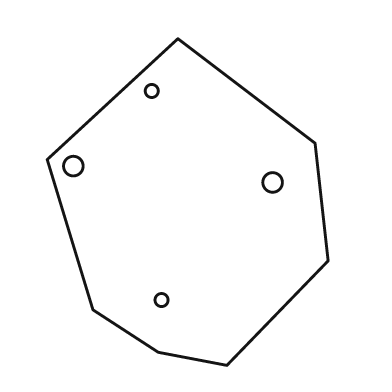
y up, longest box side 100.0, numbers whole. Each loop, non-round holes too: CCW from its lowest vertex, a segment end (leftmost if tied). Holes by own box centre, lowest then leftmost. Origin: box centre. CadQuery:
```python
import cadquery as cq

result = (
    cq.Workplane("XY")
    .moveTo(12.0, -50.0)
    .lineTo(43.0, -18.0)
    .lineTo(39.0, 18.0)
    .lineTo(-3.0, 50.0)
    .lineTo(-43.0, 13.0)
    .lineTo(-29.0, -33.0)
    .lineTo(-9.0, -46.0)
    .close()
    .moveTo(-8.0, -30.0)
    .circle(2.0)
    .moveTo(26.0, 6.0)
    .circle(3.0)
    .moveTo(-35.0, 11.0)
    .circle(3.0)
    .moveTo(-11.0, 34.0)
    .circle(2.0)
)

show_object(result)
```